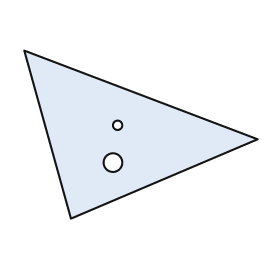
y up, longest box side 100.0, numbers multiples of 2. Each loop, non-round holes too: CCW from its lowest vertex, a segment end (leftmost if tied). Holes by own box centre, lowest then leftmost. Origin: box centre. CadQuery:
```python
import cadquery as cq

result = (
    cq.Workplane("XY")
    .moveTo(-30.0, -36.0)
    .lineTo(50.0, -2.0)
    .lineTo(-50.0, 36.0)
    .close()
    .moveTo(-12.0, -12.0)
    .circle(4.0)
    .moveTo(-10.0, 4.0)
    .circle(2.0)
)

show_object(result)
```